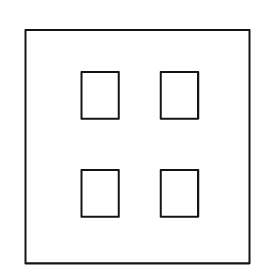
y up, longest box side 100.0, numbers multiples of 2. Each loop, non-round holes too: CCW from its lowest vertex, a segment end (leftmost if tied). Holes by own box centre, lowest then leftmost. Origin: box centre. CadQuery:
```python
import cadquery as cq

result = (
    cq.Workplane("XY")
    .moveTo(-48.0, -50.0)
    .lineTo(48.0, -50.0)
    .lineTo(48.0, 50.0)
    .lineTo(-48.0, 50.0)
    .close()
    .moveTo(-24.0, -30.0)
    .lineTo(-8.0, -30.0)
    .lineTo(-8.0, -10.0)
    .lineTo(-24.0, -10.0)
    .close()
    .moveTo(10.0, -30.0)
    .lineTo(26.0, -30.0)
    .lineTo(26.0, -10.0)
    .lineTo(10.0, -10.0)
    .close()
    .moveTo(-24.0, 12.0)
    .lineTo(-8.0, 12.0)
    .lineTo(-8.0, 32.0)
    .lineTo(-24.0, 32.0)
    .close()
    .moveTo(10.0, 12.0)
    .lineTo(26.0, 12.0)
    .lineTo(26.0, 32.0)
    .lineTo(10.0, 32.0)
    .close()
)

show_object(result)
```